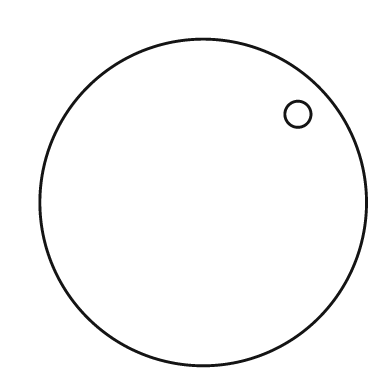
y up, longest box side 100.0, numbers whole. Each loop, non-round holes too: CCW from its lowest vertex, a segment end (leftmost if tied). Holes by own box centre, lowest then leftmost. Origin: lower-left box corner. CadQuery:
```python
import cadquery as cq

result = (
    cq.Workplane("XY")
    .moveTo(50.0, 50.0)
    .circle(50.0)
    .moveTo(79.0, 77.0)
    .circle(4.0)
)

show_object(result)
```